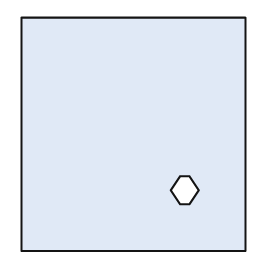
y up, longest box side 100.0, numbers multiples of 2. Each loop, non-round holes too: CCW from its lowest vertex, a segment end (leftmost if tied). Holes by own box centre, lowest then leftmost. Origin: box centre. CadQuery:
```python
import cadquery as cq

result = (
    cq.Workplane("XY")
    .moveTo(-48.0, -50.0)
    .lineTo(48.0, -50.0)
    .lineTo(48.0, 50.0)
    .lineTo(-48.0, 50.0)
    .close()
    .moveTo(20.0, -30.0)
    .lineTo(24.0, -30.0)
    .lineTo(28.0, -24.0)
    .lineTo(24.0, -18.0)
    .lineTo(20.0, -18.0)
    .lineTo(16.0, -24.0)
    .close()
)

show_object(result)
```